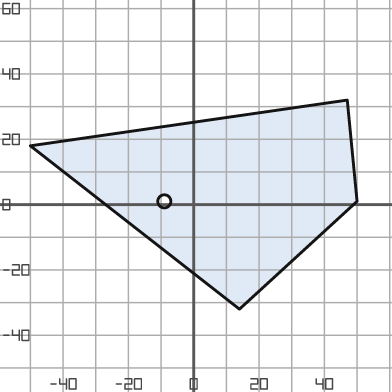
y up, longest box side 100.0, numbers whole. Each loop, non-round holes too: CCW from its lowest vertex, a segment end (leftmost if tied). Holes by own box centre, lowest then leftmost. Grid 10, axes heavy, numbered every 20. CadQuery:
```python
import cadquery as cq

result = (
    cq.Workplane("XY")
    .moveTo(14.0, -32.0)
    .lineTo(50.0, 1.0)
    .lineTo(47.0, 32.0)
    .lineTo(-50.0, 18.0)
    .close()
    .moveTo(-9.0, 1.0)
    .circle(2.0)
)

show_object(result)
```